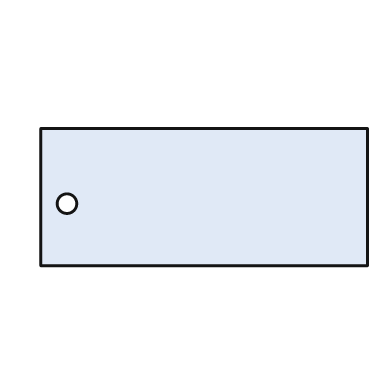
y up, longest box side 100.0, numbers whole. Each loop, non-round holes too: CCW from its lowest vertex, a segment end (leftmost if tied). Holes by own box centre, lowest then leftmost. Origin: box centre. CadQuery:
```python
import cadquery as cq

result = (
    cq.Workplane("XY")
    .moveTo(-50.0, -21.0)
    .lineTo(50.0, -21.0)
    .lineTo(50.0, 21.0)
    .lineTo(-50.0, 21.0)
    .close()
    .moveTo(-42.0, -2.0)
    .circle(3.0)
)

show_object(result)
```